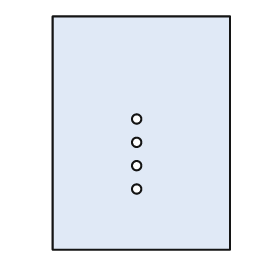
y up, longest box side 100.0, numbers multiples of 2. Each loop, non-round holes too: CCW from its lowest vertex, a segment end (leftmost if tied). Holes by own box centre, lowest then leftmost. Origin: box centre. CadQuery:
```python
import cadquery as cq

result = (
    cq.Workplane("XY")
    .moveTo(-38.0, -50.0)
    .lineTo(38.0, -50.0)
    .lineTo(38.0, 50.0)
    .lineTo(-38.0, 50.0)
    .close()
    .moveTo(-2.0, -24.0)
    .circle(2.0)
    .moveTo(-2.0, -14.0)
    .circle(2.0)
    .moveTo(-2.0, -4.0)
    .circle(2.0)
    .moveTo(-2.0, 6.0)
    .circle(2.0)
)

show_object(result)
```